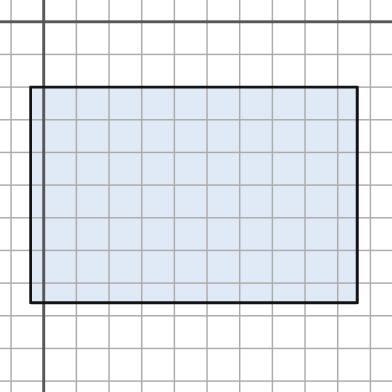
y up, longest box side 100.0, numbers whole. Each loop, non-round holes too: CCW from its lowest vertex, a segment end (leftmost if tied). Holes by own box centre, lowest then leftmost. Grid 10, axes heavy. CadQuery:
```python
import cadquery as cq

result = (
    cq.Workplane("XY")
    .moveTo(-4.0, -86.0)
    .lineTo(96.0, -86.0)
    .lineTo(96.0, -20.0)
    .lineTo(-4.0, -20.0)
    .close()
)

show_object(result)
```